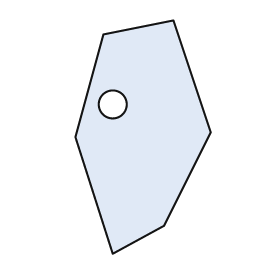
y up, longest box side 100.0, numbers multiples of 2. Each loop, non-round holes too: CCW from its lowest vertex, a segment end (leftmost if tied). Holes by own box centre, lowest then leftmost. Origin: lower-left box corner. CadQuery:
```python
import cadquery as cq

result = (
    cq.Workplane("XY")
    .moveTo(16.0, 0.0)
    .lineTo(38.0, 12.0)
    .lineTo(58.0, 52.0)
    .lineTo(42.0, 100.0)
    .lineTo(12.0, 94.0)
    .lineTo(0.0, 50.0)
    .close()
    .moveTo(16.0, 64.0)
    .circle(6.0)
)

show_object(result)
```